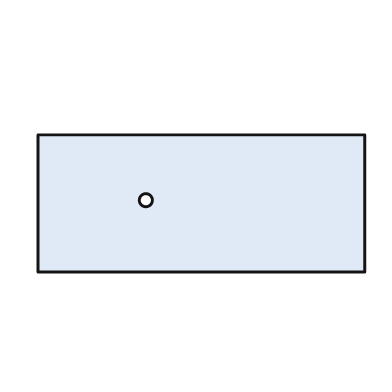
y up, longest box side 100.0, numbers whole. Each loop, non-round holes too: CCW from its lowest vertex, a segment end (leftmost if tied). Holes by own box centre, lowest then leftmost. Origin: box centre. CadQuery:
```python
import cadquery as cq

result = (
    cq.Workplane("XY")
    .moveTo(-50.0, -21.0)
    .lineTo(50.0, -21.0)
    .lineTo(50.0, 21.0)
    .lineTo(-50.0, 21.0)
    .close()
    .moveTo(-17.0, 1.0)
    .circle(2.0)
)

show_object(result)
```